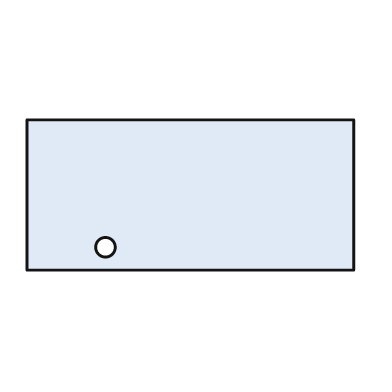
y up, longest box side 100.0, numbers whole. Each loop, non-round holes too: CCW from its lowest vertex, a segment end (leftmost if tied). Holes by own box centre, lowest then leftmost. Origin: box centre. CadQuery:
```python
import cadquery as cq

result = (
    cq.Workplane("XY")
    .moveTo(-50.0, -23.0)
    .lineTo(50.0, -23.0)
    .lineTo(50.0, 23.0)
    .lineTo(-50.0, 23.0)
    .close()
    .moveTo(-26.0, -16.0)
    .circle(3.0)
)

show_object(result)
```